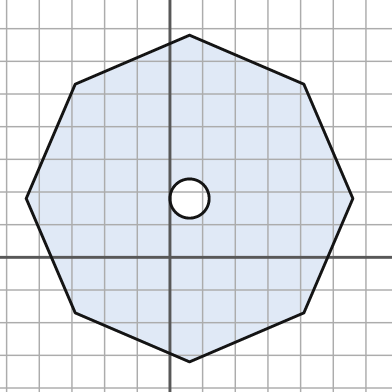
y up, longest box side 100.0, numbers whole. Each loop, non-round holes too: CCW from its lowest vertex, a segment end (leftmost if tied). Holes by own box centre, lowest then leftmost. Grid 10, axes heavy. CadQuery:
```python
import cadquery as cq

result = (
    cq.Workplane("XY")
    .moveTo(6.0, -32.0)
    .lineTo(41.0, -17.0)
    .lineTo(56.0, 18.0)
    .lineTo(41.0, 53.0)
    .lineTo(6.0, 68.0)
    .lineTo(-29.0, 53.0)
    .lineTo(-44.0, 18.0)
    .lineTo(-29.0, -17.0)
    .close()
    .moveTo(6.0, 18.0)
    .circle(6.0)
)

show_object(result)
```